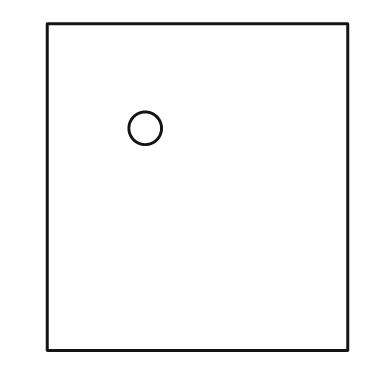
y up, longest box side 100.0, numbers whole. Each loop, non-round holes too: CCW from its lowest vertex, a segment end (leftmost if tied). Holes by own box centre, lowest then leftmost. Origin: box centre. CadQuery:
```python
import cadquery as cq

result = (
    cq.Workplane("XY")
    .moveTo(-46.0, -50.0)
    .lineTo(46.0, -50.0)
    .lineTo(46.0, 50.0)
    .lineTo(-46.0, 50.0)
    .close()
    .moveTo(-16.0, 18.0)
    .circle(5.0)
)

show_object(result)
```